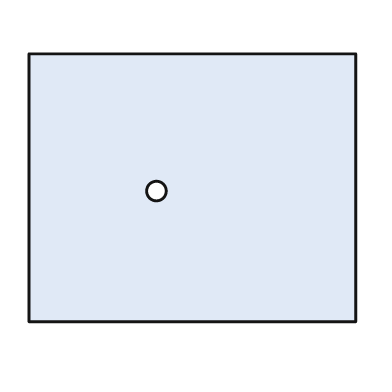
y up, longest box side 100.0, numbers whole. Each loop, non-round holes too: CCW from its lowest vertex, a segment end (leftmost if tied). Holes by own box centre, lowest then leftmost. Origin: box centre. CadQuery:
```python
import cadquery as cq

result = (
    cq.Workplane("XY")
    .moveTo(-50.0, -41.0)
    .lineTo(50.0, -41.0)
    .lineTo(50.0, 41.0)
    .lineTo(-50.0, 41.0)
    .close()
    .moveTo(-11.0, -1.0)
    .circle(3.0)
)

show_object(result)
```